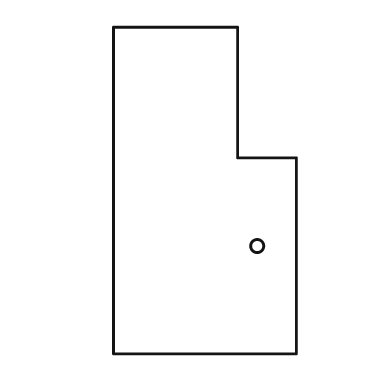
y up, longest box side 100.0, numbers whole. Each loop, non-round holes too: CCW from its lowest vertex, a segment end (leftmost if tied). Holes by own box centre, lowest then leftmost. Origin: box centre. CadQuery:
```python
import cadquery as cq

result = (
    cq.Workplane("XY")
    .moveTo(-28.0, -50.0)
    .lineTo(28.0, -50.0)
    .lineTo(28.0, 10.0)
    .lineTo(10.0, 10.0)
    .lineTo(10.0, 50.0)
    .lineTo(-28.0, 50.0)
    .close()
    .moveTo(16.0, -17.0)
    .circle(2.0)
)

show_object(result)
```